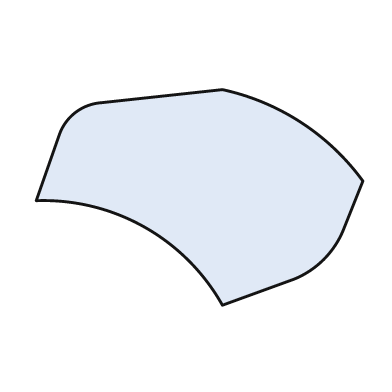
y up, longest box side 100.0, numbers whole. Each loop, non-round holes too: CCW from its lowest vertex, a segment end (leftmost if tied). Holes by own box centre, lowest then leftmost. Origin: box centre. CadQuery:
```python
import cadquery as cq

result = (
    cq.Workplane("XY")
    .moveTo(7.0, -33.0)
    .lineTo(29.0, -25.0)
    .threePointArc((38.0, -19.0), (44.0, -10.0))
    .lineTo(50.0, 5.0)
    .threePointArc((31.0, 23.0), (7.0, 33.0))
    .lineTo(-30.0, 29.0)
    .threePointArc((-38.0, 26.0), (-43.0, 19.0))
    .lineTo(-50.0, -1.0)
    .threePointArc((-17.0, -9.0), (7.0, -33.0))
    .close()
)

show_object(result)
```